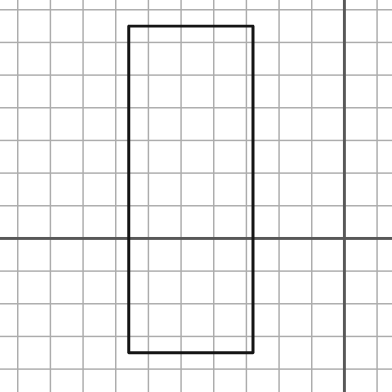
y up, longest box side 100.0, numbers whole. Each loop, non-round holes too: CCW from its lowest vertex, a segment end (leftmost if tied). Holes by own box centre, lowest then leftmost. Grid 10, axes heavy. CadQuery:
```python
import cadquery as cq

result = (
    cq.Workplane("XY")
    .moveTo(-66.0, -35.0)
    .lineTo(-28.0, -35.0)
    .lineTo(-28.0, 65.0)
    .lineTo(-66.0, 65.0)
    .close()
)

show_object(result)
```